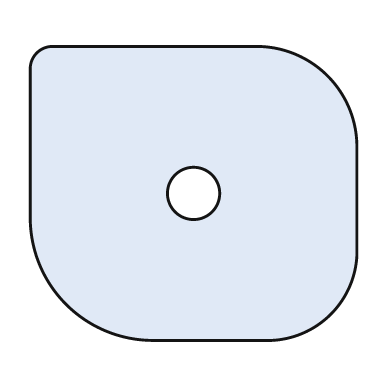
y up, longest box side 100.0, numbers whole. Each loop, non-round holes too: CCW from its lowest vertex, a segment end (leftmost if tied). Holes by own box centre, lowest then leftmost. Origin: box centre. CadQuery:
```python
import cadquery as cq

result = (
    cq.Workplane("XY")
    .moveTo(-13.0, -45.0)
    .lineTo(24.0, -45.0)
    .threePointArc((42.0, -37.0), (50.0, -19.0))
    .lineTo(50.0, 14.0)
    .threePointArc((41.0, 36.0), (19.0, 45.0))
    .lineTo(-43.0, 45.0)
    .threePointArc((-48.0, 43.0), (-50.0, 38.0))
    .lineTo(-50.0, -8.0)
    .threePointArc((-39.0, -34.0), (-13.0, -45.0))
    .close()
    .moveTo(0.0, 0.0)
    .circle(8.0)
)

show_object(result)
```